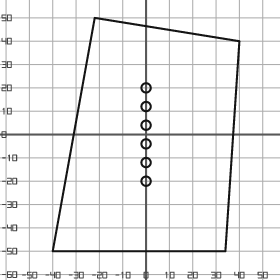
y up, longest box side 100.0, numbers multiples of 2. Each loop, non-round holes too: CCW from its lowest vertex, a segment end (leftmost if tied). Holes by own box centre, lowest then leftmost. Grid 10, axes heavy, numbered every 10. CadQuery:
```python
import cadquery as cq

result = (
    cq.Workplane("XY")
    .moveTo(-40.0, -50.0)
    .lineTo(34.0, -50.0)
    .lineTo(40.0, 40.0)
    .lineTo(-22.0, 50.0)
    .close()
    .moveTo(0.0, -20.0)
    .circle(2.0)
    .moveTo(0.0, -12.0)
    .circle(2.0)
    .moveTo(0.0, -4.0)
    .circle(2.0)
    .moveTo(0.0, 4.0)
    .circle(2.0)
    .moveTo(0.0, 12.0)
    .circle(2.0)
    .moveTo(0.0, 20.0)
    .circle(2.0)
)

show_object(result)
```